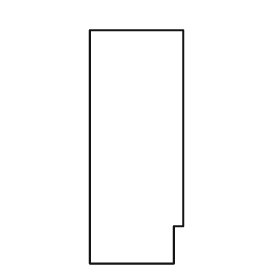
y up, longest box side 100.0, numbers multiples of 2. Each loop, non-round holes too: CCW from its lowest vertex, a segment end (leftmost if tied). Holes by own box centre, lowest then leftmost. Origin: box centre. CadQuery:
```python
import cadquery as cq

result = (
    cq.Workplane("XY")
    .moveTo(-20.0, -50.0)
    .lineTo(16.0, -50.0)
    .lineTo(16.0, -34.0)
    .lineTo(20.0, -34.0)
    .lineTo(20.0, 50.0)
    .lineTo(-20.0, 50.0)
    .close()
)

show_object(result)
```